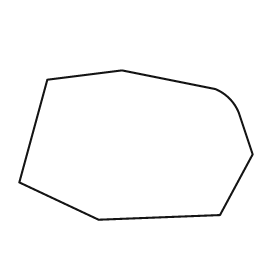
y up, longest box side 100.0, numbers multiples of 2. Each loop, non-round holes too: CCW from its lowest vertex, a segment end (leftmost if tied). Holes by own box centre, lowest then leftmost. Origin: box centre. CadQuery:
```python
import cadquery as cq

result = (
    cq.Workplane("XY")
    .moveTo(-16.0, -32.0)
    .lineTo(36.0, -30.0)
    .lineTo(50.0, -4.0)
    .lineTo(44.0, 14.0)
    .threePointArc((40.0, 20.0), (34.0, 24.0))
    .lineTo(-6.0, 32.0)
    .lineTo(-38.0, 28.0)
    .lineTo(-50.0, -16.0)
    .close()
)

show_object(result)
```